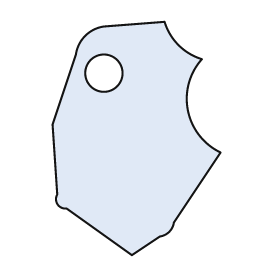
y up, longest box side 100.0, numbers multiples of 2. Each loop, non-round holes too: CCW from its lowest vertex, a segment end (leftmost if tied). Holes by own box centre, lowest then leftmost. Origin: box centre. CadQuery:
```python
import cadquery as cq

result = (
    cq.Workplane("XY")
    .moveTo(-2.0, -50.0)
    .lineTo(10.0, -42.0)
    .threePointArc((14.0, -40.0), (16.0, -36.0))
    .lineTo(36.0, -6.0)
    .threePointArc((22.0, 12.0), (28.0, 34.0))
    .threePointArc((18.0, 40.0), (12.0, 50.0))
    .lineTo(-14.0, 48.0)
    .threePointArc((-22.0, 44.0), (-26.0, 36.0))
    .lineTo(-36.0, 6.0)
    .lineTo(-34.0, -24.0)
    .threePointArc((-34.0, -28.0), (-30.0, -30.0))
    .close()
    .moveTo(-14.0, 28.0)
    .circle(8.0)
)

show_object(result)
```